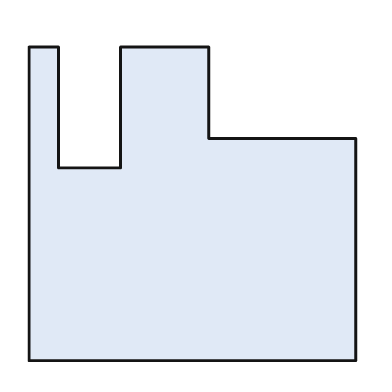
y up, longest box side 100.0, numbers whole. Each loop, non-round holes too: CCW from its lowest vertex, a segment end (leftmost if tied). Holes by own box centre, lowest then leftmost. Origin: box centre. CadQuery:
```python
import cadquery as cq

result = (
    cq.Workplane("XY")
    .moveTo(-50.0, -48.0)
    .lineTo(50.0, -48.0)
    .lineTo(50.0, 20.0)
    .lineTo(5.0, 20.0)
    .lineTo(5.0, 48.0)
    .lineTo(-22.0, 48.0)
    .lineTo(-22.0, 11.0)
    .lineTo(-41.0, 11.0)
    .lineTo(-41.0, 48.0)
    .lineTo(-50.0, 48.0)
    .close()
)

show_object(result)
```